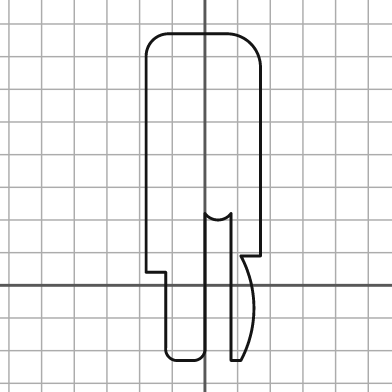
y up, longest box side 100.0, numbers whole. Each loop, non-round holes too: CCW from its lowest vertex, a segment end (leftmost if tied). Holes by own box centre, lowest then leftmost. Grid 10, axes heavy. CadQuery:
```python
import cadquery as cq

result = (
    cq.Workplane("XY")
    .moveTo(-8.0, -23.0)
    .lineTo(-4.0, -23.0)
    .threePointArc((-1.0, -22.0), (0.0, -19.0))
    .lineTo(0.0, 22.0)
    .threePointArc((4.0, 20.0), (8.0, 22.0))
    .lineTo(8.0, -23.0)
    .lineTo(11.0, -23.0)
    .threePointArc((15.0, -7.0), (11.0, 9.0))
    .lineTo(17.0, 9.0)
    .lineTo(17.0, 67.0)
    .threePointArc((14.0, 74.0), (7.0, 77.0))
    .lineTo(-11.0, 77.0)
    .threePointArc((-16.0, 75.0), (-18.0, 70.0))
    .lineTo(-18.0, 4.0)
    .lineTo(-12.0, 4.0)
    .lineTo(-12.0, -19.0)
    .threePointArc((-11.0, -22.0), (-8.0, -23.0))
    .close()
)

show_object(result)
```